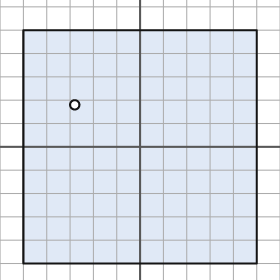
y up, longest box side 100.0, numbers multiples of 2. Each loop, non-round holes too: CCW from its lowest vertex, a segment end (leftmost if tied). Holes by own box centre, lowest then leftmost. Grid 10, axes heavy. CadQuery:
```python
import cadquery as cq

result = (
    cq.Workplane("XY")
    .moveTo(-50.0, -50.0)
    .lineTo(50.0, -50.0)
    .lineTo(50.0, 50.0)
    .lineTo(-50.0, 50.0)
    .close()
    .moveTo(-28.0, 18.0)
    .circle(2.0)
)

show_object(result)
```